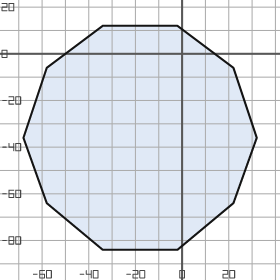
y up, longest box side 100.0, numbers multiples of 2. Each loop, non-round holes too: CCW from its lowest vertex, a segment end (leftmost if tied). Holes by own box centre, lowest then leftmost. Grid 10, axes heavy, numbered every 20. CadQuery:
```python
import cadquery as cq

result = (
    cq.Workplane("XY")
    .moveTo(-34.0, -84.0)
    .lineTo(-2.0, -84.0)
    .lineTo(22.0, -64.0)
    .lineTo(32.0, -36.0)
    .lineTo(22.0, -6.0)
    .lineTo(-2.0, 12.0)
    .lineTo(-34.0, 12.0)
    .lineTo(-58.0, -6.0)
    .lineTo(-68.0, -36.0)
    .lineTo(-58.0, -64.0)
    .close()
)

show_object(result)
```